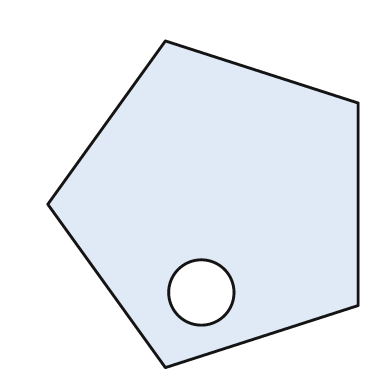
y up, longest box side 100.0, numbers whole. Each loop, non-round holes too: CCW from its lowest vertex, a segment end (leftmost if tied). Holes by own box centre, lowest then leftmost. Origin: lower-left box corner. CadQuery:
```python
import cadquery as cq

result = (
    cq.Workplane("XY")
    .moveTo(36.0, 0.0)
    .lineTo(95.0, 19.0)
    .lineTo(95.0, 81.0)
    .lineTo(36.0, 100.0)
    .lineTo(0.0, 50.0)
    .close()
    .moveTo(47.0, 23.0)
    .circle(10.0)
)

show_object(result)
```